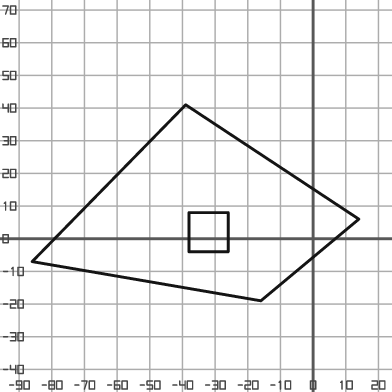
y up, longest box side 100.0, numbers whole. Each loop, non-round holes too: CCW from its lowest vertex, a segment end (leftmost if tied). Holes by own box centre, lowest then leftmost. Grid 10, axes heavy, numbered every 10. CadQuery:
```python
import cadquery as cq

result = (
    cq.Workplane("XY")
    .moveTo(-16.0, -19.0)
    .lineTo(14.0, 6.0)
    .lineTo(-39.0, 41.0)
    .lineTo(-86.0, -7.0)
    .close()
    .moveTo(-38.0, -4.0)
    .lineTo(-26.0, -4.0)
    .lineTo(-26.0, 8.0)
    .lineTo(-38.0, 8.0)
    .close()
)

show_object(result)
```